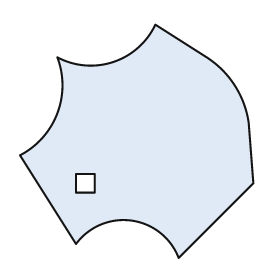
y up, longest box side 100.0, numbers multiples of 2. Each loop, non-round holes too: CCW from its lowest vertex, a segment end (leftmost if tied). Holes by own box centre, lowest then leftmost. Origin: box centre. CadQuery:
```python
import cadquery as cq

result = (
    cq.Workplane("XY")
    .moveTo(18.0, -50.0)
    .lineTo(50.0, -18.0)
    .lineTo(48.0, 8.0)
    .threePointArc((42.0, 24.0), (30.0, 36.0))
    .lineTo(8.0, 50.0)
    .threePointArc((-10.0, 34.0), (-34.0, 36.0))
    .threePointArc((-34.0, 12.0), (-50.0, -6.0))
    .lineTo(-26.0, -44.0)
    .threePointArc((-2.0, -34.0), (18.0, -50.0))
    .close()
    .moveTo(-26.0, -22.0)
    .lineTo(-18.0, -22.0)
    .lineTo(-18.0, -14.0)
    .lineTo(-26.0, -14.0)
    .close()
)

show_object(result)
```